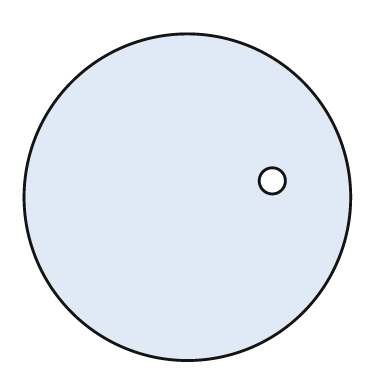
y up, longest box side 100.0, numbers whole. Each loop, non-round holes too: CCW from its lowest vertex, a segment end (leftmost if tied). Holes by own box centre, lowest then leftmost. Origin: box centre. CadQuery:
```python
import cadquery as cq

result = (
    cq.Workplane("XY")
    .moveTo(0.0, 0.0)
    .circle(50.0)
    .moveTo(26.0, 5.0)
    .circle(4.0)
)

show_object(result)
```